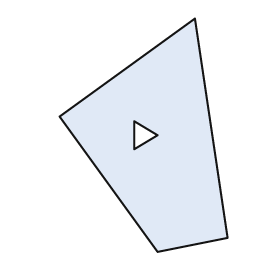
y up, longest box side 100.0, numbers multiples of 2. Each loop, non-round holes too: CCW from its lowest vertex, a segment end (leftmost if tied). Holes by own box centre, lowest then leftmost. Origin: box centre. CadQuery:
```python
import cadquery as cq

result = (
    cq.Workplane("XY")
    .moveTo(6.0, -50.0)
    .lineTo(36.0, -44.0)
    .lineTo(22.0, 50.0)
    .lineTo(-36.0, 8.0)
    .close()
    .moveTo(-4.0, -6.0)
    .lineTo(6.0, 0.0)
    .lineTo(-4.0, 6.0)
    .close()
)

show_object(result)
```